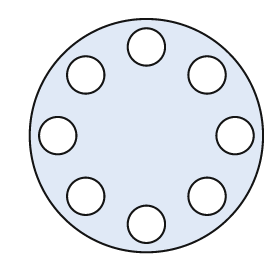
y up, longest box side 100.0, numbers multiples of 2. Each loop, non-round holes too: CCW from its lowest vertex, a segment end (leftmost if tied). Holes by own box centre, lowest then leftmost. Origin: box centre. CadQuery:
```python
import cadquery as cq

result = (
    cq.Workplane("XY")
    .moveTo(0.0, 0.0)
    .circle(50.0)
    .moveTo(0.0, -38.0)
    .circle(8.0)
    .moveTo(-26.0, -26.0)
    .circle(8.0)
    .moveTo(26.0, -26.0)
    .circle(8.0)
    .moveTo(-38.0, 0.0)
    .circle(8.0)
    .moveTo(38.0, 0.0)
    .circle(8.0)
    .moveTo(-26.0, 26.0)
    .circle(8.0)
    .moveTo(26.0, 26.0)
    .circle(8.0)
    .moveTo(0.0, 38.0)
    .circle(8.0)
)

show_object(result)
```